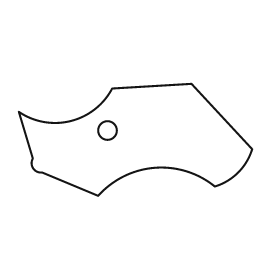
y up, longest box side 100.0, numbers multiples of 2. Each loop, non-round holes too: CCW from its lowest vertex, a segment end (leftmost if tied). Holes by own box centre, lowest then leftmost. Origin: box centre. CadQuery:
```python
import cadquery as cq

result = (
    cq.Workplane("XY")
    .moveTo(-16.0, -24.0)
    .threePointArc((8.0, -12.0), (34.0, -20.0))
    .threePointArc((44.0, -14.0), (50.0, -4.0))
    .lineTo(24.0, 24.0)
    .lineTo(-10.0, 22.0)
    .threePointArc((-28.0, 8.0), (-50.0, 12.0))
    .lineTo(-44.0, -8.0)
    .threePointArc((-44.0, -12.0), (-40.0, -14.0))
    .close()
    .moveTo(-12.0, 4.0)
    .circle(4.0)
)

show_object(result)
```